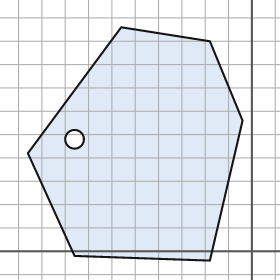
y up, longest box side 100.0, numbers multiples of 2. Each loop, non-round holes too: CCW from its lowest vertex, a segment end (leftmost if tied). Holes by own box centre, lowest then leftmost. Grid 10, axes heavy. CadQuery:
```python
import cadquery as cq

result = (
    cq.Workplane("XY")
    .moveTo(-18.0, -4.0)
    .lineTo(-4.0, 56.0)
    .lineTo(-18.0, 90.0)
    .lineTo(-56.0, 96.0)
    .lineTo(-96.0, 42.0)
    .lineTo(-76.0, -2.0)
    .close()
    .moveTo(-76.0, 48.0)
    .circle(4.0)
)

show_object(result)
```